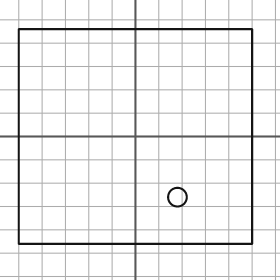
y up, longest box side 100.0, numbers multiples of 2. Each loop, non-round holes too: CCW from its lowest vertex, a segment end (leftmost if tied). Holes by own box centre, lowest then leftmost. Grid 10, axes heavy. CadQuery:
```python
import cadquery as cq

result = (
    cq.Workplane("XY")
    .moveTo(-50.0, -46.0)
    .lineTo(50.0, -46.0)
    .lineTo(50.0, 46.0)
    .lineTo(-50.0, 46.0)
    .close()
    .moveTo(18.0, -26.0)
    .circle(4.0)
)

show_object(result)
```